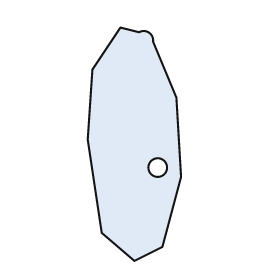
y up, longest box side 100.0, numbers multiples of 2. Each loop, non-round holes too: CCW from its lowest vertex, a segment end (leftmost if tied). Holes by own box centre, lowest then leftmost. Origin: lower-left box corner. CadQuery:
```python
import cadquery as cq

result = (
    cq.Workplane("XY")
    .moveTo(20.0, 0.0)
    .lineTo(32.0, 6.0)
    .lineTo(40.0, 36.0)
    .lineTo(38.0, 70.0)
    .lineTo(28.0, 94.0)
    .threePointArc((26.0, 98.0), (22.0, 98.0))
    .lineTo(14.0, 100.0)
    .lineTo(2.0, 82.0)
    .lineTo(0.0, 52.0)
    .lineTo(6.0, 12.0)
    .close()
    .moveTo(30.0, 40.0)
    .circle(4.0)
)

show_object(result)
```